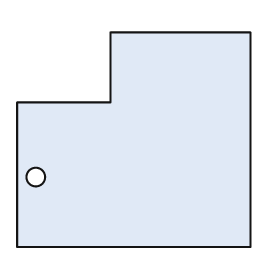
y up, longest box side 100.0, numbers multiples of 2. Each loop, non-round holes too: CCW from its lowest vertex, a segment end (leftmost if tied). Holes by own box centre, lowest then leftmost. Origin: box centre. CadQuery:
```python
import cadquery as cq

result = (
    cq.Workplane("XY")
    .moveTo(-50.0, -46.0)
    .lineTo(50.0, -46.0)
    .lineTo(50.0, 46.0)
    .lineTo(-10.0, 46.0)
    .lineTo(-10.0, 16.0)
    .lineTo(-50.0, 16.0)
    .close()
    .moveTo(-42.0, -16.0)
    .circle(4.0)
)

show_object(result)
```